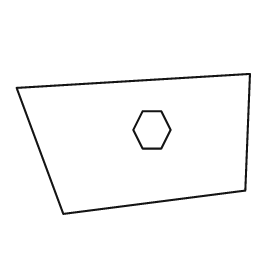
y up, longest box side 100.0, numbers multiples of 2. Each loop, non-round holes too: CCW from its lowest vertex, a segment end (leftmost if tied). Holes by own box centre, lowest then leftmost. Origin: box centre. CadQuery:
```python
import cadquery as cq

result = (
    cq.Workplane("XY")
    .moveTo(-30.0, -30.0)
    .lineTo(48.0, -20.0)
    .lineTo(50.0, 30.0)
    .lineTo(-50.0, 24.0)
    .close()
    .moveTo(4.0, -2.0)
    .lineTo(12.0, -2.0)
    .lineTo(16.0, 6.0)
    .lineTo(12.0, 14.0)
    .lineTo(4.0, 14.0)
    .lineTo(0.0, 6.0)
    .close()
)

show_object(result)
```